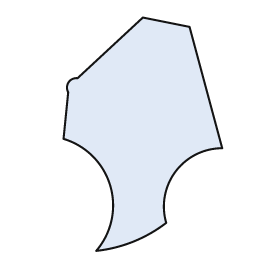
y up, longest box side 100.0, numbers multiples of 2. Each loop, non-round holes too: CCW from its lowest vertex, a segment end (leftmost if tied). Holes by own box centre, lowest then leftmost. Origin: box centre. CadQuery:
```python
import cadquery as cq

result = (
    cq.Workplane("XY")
    .moveTo(-20.0, -50.0)
    .threePointArc((-4.0, -46.0), (10.0, -38.0))
    .threePointArc((14.0, -16.0), (34.0, -6.0))
    .lineTo(20.0, 46.0)
    .lineTo(0.0, 50.0)
    .lineTo(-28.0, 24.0)
    .threePointArc((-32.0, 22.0), (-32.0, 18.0))
    .lineTo(-34.0, -2.0)
    .threePointArc((-14.0, -22.0), (-20.0, -50.0))
    .close()
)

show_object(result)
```